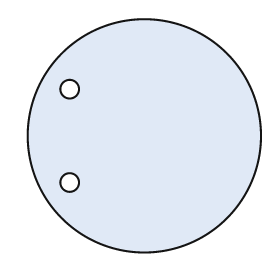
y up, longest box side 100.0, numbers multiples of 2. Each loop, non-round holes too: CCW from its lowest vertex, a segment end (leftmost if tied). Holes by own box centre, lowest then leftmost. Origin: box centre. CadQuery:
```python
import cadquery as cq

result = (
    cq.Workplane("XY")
    .moveTo(0.0, 0.0)
    .circle(50.0)
    .moveTo(-32.0, -20.0)
    .circle(4.0)
    .moveTo(-32.0, 20.0)
    .circle(4.0)
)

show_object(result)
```